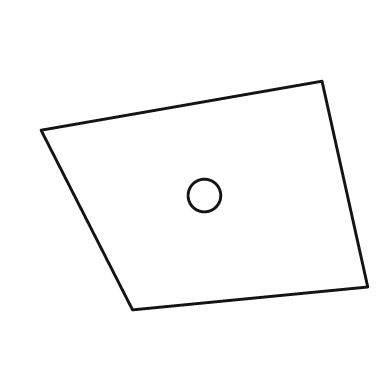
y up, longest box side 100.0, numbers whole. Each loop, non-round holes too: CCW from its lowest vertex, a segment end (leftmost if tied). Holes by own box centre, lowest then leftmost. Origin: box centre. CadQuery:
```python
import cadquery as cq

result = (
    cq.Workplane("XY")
    .moveTo(-22.0, -35.0)
    .lineTo(50.0, -28.0)
    .lineTo(36.0, 35.0)
    .lineTo(-50.0, 20.0)
    .close()
    .moveTo(0.0, 0.0)
    .circle(5.0)
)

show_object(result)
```